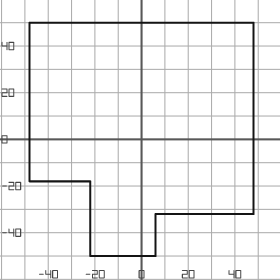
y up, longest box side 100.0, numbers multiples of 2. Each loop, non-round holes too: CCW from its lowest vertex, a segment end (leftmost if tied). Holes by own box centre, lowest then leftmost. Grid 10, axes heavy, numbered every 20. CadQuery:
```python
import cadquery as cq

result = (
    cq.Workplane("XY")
    .moveTo(-22.0, -50.0)
    .lineTo(6.0, -50.0)
    .lineTo(6.0, -32.0)
    .lineTo(48.0, -32.0)
    .lineTo(48.0, 50.0)
    .lineTo(-48.0, 50.0)
    .lineTo(-48.0, -18.0)
    .lineTo(-22.0, -18.0)
    .close()
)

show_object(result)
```